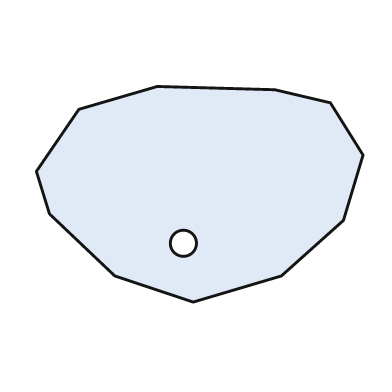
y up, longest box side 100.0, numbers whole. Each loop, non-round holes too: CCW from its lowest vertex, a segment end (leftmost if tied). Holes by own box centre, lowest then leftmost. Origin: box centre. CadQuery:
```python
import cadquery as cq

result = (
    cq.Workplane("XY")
    .moveTo(-2.0, -33.0)
    .lineTo(25.0, -25.0)
    .lineTo(44.0, -8.0)
    .lineTo(50.0, 12.0)
    .lineTo(40.0, 28.0)
    .lineTo(23.0, 32.0)
    .lineTo(-13.0, 33.0)
    .lineTo(-37.0, 26.0)
    .lineTo(-50.0, 7.0)
    .lineTo(-46.0, -6.0)
    .lineTo(-26.0, -25.0)
    .close()
    .moveTo(-5.0, -15.0)
    .circle(4.0)
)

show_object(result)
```